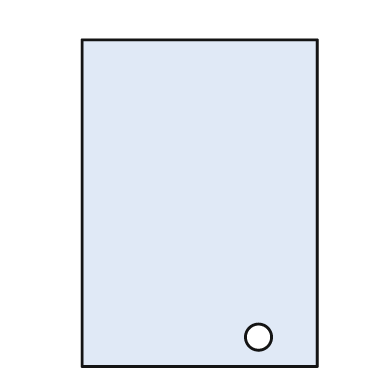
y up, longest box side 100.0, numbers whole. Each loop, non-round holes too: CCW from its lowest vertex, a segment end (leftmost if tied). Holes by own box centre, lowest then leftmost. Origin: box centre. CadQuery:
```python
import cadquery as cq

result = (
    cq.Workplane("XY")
    .moveTo(-36.0, -50.0)
    .lineTo(36.0, -50.0)
    .lineTo(36.0, 50.0)
    .lineTo(-36.0, 50.0)
    .close()
    .moveTo(18.0, -41.0)
    .circle(4.0)
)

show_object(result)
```